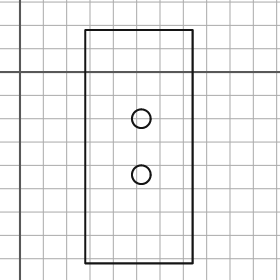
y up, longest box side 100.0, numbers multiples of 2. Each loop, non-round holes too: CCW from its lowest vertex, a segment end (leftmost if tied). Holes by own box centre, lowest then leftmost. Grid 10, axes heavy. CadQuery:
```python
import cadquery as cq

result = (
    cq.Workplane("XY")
    .moveTo(28.0, -82.0)
    .lineTo(74.0, -82.0)
    .lineTo(74.0, 18.0)
    .lineTo(28.0, 18.0)
    .close()
    .moveTo(52.0, -44.0)
    .circle(4.0)
    .moveTo(52.0, -20.0)
    .circle(4.0)
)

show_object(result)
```